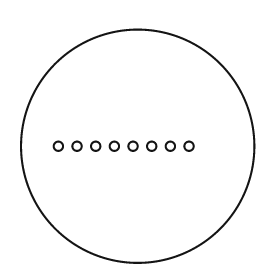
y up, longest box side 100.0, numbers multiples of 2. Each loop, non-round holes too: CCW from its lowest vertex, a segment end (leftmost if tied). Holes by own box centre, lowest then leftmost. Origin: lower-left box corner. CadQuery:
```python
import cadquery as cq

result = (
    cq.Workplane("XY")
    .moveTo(50.0, 50.0)
    .circle(50.0)
    .moveTo(16.0, 50.0)
    .circle(2.0)
    .moveTo(24.0, 50.0)
    .circle(2.0)
    .moveTo(32.0, 50.0)
    .circle(2.0)
    .moveTo(40.0, 50.0)
    .circle(2.0)
    .moveTo(48.0, 50.0)
    .circle(2.0)
    .moveTo(56.0, 50.0)
    .circle(2.0)
    .moveTo(64.0, 50.0)
    .circle(2.0)
    .moveTo(72.0, 50.0)
    .circle(2.0)
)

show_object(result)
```